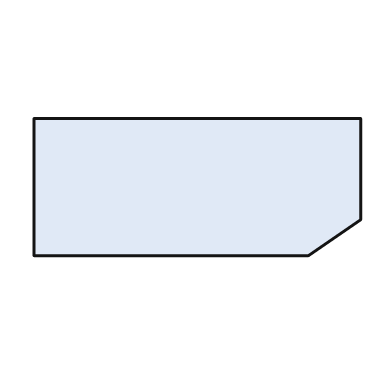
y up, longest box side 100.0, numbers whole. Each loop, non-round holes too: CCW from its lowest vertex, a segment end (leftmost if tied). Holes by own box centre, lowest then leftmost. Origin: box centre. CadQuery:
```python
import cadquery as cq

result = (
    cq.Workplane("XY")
    .moveTo(-50.0, -21.0)
    .lineTo(34.0, -21.0)
    .lineTo(50.0, -10.0)
    .lineTo(50.0, 21.0)
    .lineTo(-50.0, 21.0)
    .close()
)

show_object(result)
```